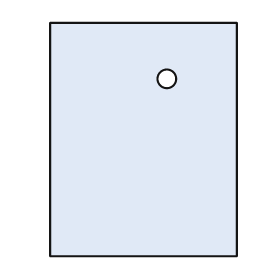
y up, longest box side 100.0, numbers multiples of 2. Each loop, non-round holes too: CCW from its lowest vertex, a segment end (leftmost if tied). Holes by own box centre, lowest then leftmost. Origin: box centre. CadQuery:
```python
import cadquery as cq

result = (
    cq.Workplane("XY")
    .moveTo(-40.0, -50.0)
    .lineTo(40.0, -50.0)
    .lineTo(40.0, 50.0)
    .lineTo(-40.0, 50.0)
    .close()
    .moveTo(10.0, 26.0)
    .circle(4.0)
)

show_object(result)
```